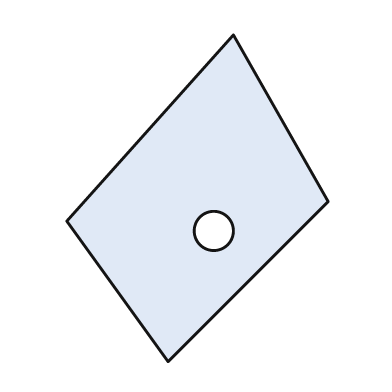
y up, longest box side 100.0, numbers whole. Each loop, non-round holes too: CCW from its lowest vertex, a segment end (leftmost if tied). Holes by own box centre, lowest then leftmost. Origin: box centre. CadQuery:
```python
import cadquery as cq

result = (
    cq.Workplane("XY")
    .moveTo(-9.0, -50.0)
    .lineTo(40.0, -1.0)
    .lineTo(11.0, 50.0)
    .lineTo(-40.0, -7.0)
    .close()
    .moveTo(5.0, -10.0)
    .circle(6.0)
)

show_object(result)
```